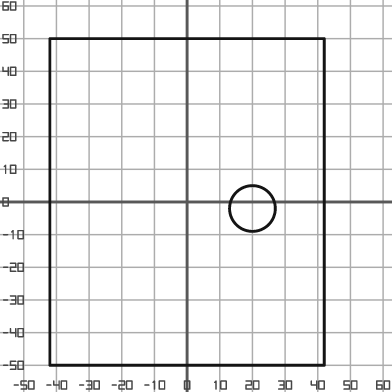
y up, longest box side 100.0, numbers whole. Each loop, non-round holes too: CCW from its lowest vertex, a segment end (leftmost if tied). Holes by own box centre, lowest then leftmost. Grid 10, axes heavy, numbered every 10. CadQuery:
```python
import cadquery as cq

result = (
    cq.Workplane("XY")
    .moveTo(-42.0, -50.0)
    .lineTo(42.0, -50.0)
    .lineTo(42.0, 50.0)
    .lineTo(-42.0, 50.0)
    .close()
    .moveTo(20.0, -2.0)
    .circle(7.0)
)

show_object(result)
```